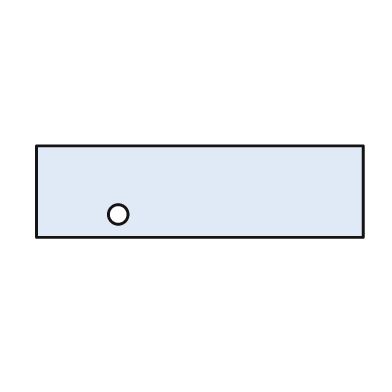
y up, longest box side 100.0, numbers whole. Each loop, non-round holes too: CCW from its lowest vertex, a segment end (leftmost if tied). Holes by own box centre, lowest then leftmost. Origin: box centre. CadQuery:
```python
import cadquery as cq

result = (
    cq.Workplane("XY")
    .moveTo(-50.0, -14.0)
    .lineTo(50.0, -14.0)
    .lineTo(50.0, 14.0)
    .lineTo(-50.0, 14.0)
    .close()
    .moveTo(-25.0, -7.0)
    .circle(3.0)
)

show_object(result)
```